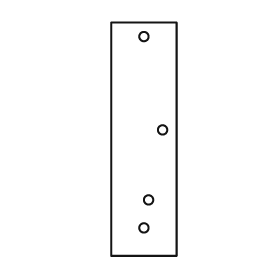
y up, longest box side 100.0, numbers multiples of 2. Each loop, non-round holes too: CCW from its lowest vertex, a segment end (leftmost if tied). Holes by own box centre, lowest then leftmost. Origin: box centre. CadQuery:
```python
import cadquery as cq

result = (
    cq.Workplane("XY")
    .moveTo(-14.0, -50.0)
    .lineTo(14.0, -50.0)
    .lineTo(14.0, 50.0)
    .lineTo(-14.0, 50.0)
    .close()
    .moveTo(0.0, -38.0)
    .circle(2.0)
    .moveTo(2.0, -26.0)
    .circle(2.0)
    .moveTo(8.0, 4.0)
    .circle(2.0)
    .moveTo(0.0, 44.0)
    .circle(2.0)
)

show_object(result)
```